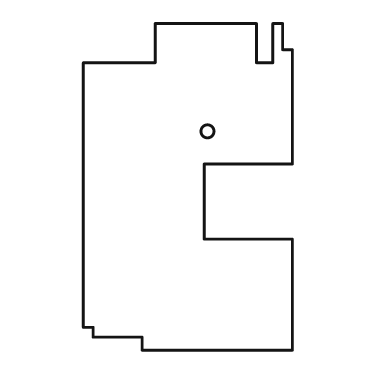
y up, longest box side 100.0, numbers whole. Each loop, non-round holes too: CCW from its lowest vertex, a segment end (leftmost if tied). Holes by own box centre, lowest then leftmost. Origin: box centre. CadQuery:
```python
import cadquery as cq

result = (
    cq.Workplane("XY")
    .moveTo(-14.0, -50.0)
    .lineTo(32.0, -50.0)
    .lineTo(32.0, -16.0)
    .lineTo(5.0, -16.0)
    .lineTo(5.0, 7.0)
    .lineTo(32.0, 7.0)
    .lineTo(32.0, 42.0)
    .lineTo(29.0, 42.0)
    .lineTo(29.0, 50.0)
    .lineTo(26.0, 50.0)
    .lineTo(26.0, 38.0)
    .lineTo(21.0, 38.0)
    .lineTo(21.0, 50.0)
    .lineTo(-10.0, 50.0)
    .lineTo(-10.0, 38.0)
    .lineTo(-32.0, 38.0)
    .lineTo(-32.0, -43.0)
    .lineTo(-29.0, -43.0)
    .lineTo(-29.0, -46.0)
    .lineTo(-14.0, -46.0)
    .close()
    .moveTo(6.0, 17.0)
    .circle(2.0)
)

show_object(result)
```